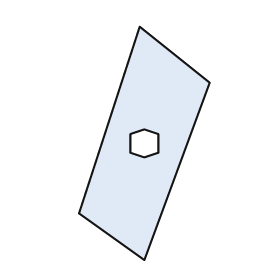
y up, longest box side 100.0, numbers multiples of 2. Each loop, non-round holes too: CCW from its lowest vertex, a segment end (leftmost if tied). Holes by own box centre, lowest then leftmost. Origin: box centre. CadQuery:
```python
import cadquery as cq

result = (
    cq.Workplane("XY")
    .moveTo(0.0, -50.0)
    .lineTo(28.0, 26.0)
    .lineTo(-2.0, 50.0)
    .lineTo(-28.0, -30.0)
    .close()
    .moveTo(0.0, -6.0)
    .lineTo(6.0, -4.0)
    .lineTo(6.0, 4.0)
    .lineTo(0.0, 6.0)
    .lineTo(-6.0, 4.0)
    .lineTo(-6.0, -4.0)
    .close()
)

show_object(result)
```